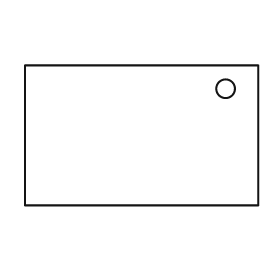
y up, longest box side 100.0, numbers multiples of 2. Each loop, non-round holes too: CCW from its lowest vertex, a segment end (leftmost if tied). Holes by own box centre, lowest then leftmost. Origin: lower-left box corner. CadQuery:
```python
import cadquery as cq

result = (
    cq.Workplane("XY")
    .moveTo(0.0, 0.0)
    .lineTo(100.0, 0.0)
    .lineTo(100.0, 60.0)
    .lineTo(0.0, 60.0)
    .close()
    .moveTo(86.0, 50.0)
    .circle(4.0)
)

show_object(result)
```